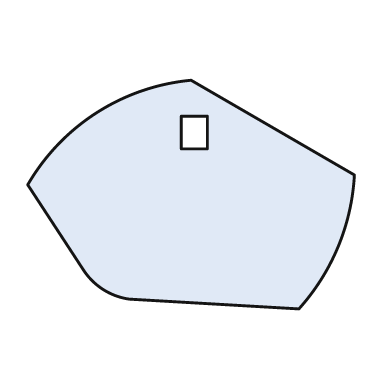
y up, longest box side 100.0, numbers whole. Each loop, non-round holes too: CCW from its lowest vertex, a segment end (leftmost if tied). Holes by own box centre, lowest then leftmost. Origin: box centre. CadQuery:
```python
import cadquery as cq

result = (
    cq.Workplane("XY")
    .moveTo(33.0, -35.0)
    .threePointArc((45.0, -16.0), (50.0, 6.0))
    .lineTo(0.0, 35.0)
    .threePointArc((-29.0, 25.0), (-50.0, 3.0))
    .lineTo(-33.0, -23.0)
    .threePointArc((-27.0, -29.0), (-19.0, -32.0))
    .close()
    .moveTo(-3.0, 14.0)
    .lineTo(5.0, 14.0)
    .lineTo(5.0, 24.0)
    .lineTo(-3.0, 24.0)
    .close()
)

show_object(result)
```